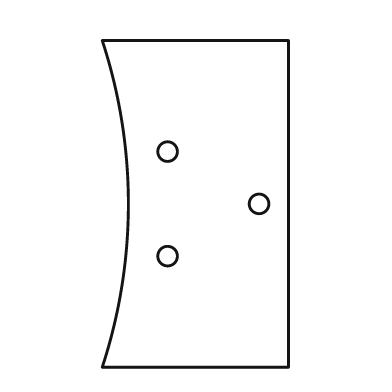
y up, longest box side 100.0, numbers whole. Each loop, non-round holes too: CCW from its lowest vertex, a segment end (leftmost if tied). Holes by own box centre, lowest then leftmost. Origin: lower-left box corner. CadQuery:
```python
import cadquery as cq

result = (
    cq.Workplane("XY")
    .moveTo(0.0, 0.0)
    .lineTo(57.0, 0.0)
    .lineTo(57.0, 100.0)
    .lineTo(0.0, 100.0)
    .threePointArc((8.0, 50.0), (0.0, 0.0))
    .close()
    .moveTo(20.0, 34.0)
    .circle(3.0)
    .moveTo(48.0, 50.0)
    .circle(3.0)
    .moveTo(20.0, 66.0)
    .circle(3.0)
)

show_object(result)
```